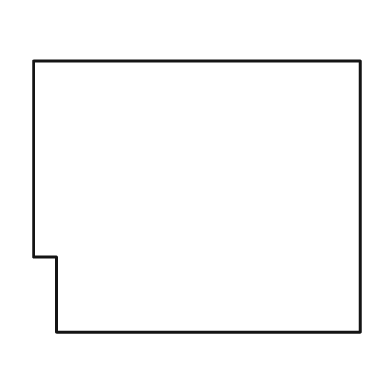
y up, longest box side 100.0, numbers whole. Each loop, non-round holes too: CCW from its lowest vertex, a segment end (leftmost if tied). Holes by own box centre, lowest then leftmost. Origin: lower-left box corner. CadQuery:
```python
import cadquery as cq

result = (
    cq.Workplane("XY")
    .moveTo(7.0, 0.0)
    .lineTo(100.0, 0.0)
    .lineTo(100.0, 83.0)
    .lineTo(0.0, 83.0)
    .lineTo(0.0, 23.0)
    .lineTo(7.0, 23.0)
    .close()
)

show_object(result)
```